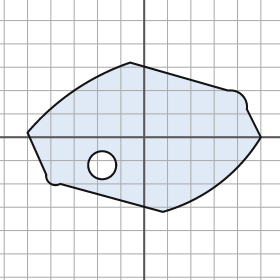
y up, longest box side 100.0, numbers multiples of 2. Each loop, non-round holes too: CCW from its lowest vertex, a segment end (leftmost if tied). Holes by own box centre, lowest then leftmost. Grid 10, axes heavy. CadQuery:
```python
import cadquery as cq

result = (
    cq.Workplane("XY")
    .moveTo(8.0, -32.0)
    .threePointArc((32.0, -20.0), (50.0, 0.0))
    .lineTo(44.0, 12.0)
    .threePointArc((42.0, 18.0), (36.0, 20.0))
    .lineTo(-6.0, 32.0)
    .threePointArc((-30.0, 20.0), (-50.0, 2.0))
    .lineTo(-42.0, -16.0)
    .threePointArc((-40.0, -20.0), (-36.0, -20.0))
    .close()
    .moveTo(-18.0, -12.0)
    .circle(6.0)
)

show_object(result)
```